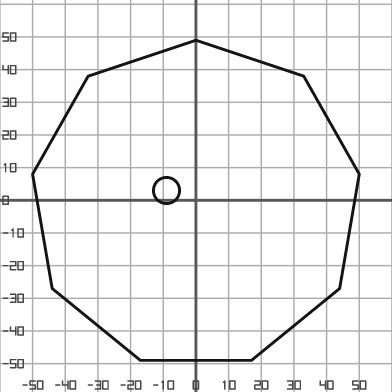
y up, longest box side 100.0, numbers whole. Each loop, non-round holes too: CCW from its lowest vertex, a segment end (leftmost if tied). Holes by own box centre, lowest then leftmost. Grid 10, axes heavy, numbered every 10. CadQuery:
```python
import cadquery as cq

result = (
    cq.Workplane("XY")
    .moveTo(-17.0, -49.0)
    .lineTo(17.0, -49.0)
    .lineTo(44.0, -27.0)
    .lineTo(50.0, 8.0)
    .lineTo(33.0, 38.0)
    .lineTo(0.0, 49.0)
    .lineTo(-33.0, 38.0)
    .lineTo(-50.0, 8.0)
    .lineTo(-44.0, -27.0)
    .close()
    .moveTo(-9.0, 3.0)
    .circle(4.0)
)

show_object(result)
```